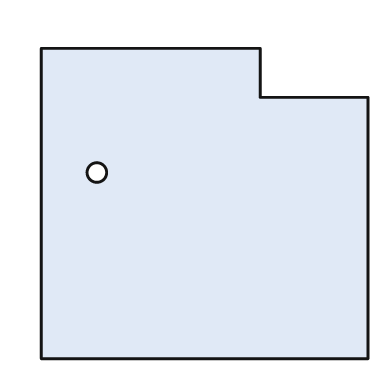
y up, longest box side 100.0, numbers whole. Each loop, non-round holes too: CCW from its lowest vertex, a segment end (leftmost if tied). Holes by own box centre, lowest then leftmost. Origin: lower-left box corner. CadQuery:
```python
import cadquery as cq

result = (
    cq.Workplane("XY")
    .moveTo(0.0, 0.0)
    .lineTo(100.0, 0.0)
    .lineTo(100.0, 80.0)
    .lineTo(67.0, 80.0)
    .lineTo(67.0, 95.0)
    .lineTo(0.0, 95.0)
    .close()
    .moveTo(17.0, 57.0)
    .circle(3.0)
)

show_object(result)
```